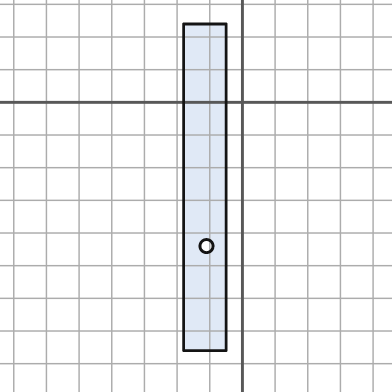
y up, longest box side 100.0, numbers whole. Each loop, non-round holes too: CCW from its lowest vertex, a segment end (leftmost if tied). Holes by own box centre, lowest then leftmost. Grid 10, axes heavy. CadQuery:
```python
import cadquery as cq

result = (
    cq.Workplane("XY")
    .moveTo(-18.0, -76.0)
    .lineTo(-5.0, -76.0)
    .lineTo(-5.0, 24.0)
    .lineTo(-18.0, 24.0)
    .close()
    .moveTo(-11.0, -44.0)
    .circle(2.0)
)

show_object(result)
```